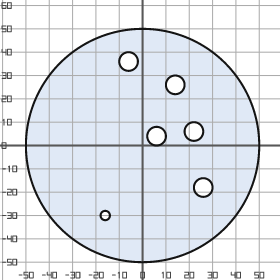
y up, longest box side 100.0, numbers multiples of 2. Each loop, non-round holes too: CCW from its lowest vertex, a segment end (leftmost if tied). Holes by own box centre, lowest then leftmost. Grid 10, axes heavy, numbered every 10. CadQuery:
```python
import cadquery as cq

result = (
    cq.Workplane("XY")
    .moveTo(0.0, 0.0)
    .circle(50.0)
    .moveTo(-16.0, -30.0)
    .circle(2.0)
    .moveTo(26.0, -18.0)
    .circle(4.0)
    .moveTo(6.0, 4.0)
    .circle(4.0)
    .moveTo(22.0, 6.0)
    .circle(4.0)
    .moveTo(14.0, 26.0)
    .circle(4.0)
    .moveTo(-6.0, 36.0)
    .circle(4.0)
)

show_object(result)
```